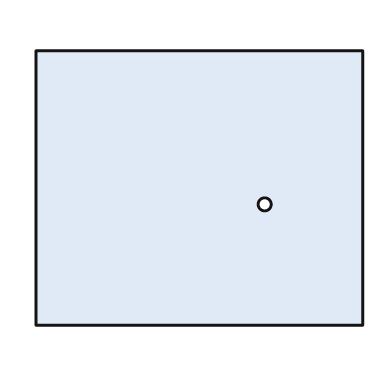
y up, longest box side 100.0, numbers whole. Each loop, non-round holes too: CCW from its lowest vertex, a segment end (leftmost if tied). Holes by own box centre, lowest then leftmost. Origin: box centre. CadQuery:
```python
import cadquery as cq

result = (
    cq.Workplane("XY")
    .moveTo(-50.0, -42.0)
    .lineTo(50.0, -42.0)
    .lineTo(50.0, 42.0)
    .lineTo(-50.0, 42.0)
    .close()
    .moveTo(20.0, -5.0)
    .circle(2.0)
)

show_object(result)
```